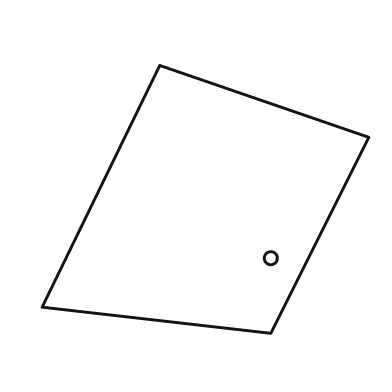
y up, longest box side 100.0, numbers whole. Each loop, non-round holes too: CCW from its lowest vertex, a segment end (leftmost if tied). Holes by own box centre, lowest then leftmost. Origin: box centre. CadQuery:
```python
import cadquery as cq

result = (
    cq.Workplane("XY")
    .moveTo(20.0, -41.0)
    .lineTo(50.0, 19.0)
    .lineTo(-14.0, 41.0)
    .lineTo(-50.0, -33.0)
    .close()
    .moveTo(20.0, -18.0)
    .circle(2.0)
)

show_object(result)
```